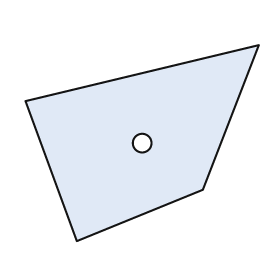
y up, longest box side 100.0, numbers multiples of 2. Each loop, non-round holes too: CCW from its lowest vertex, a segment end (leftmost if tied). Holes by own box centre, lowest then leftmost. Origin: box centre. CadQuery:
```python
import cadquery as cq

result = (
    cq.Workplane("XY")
    .moveTo(-28.0, -42.0)
    .lineTo(26.0, -20.0)
    .lineTo(50.0, 42.0)
    .lineTo(-50.0, 18.0)
    .close()
    .moveTo(0.0, 0.0)
    .circle(4.0)
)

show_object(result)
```